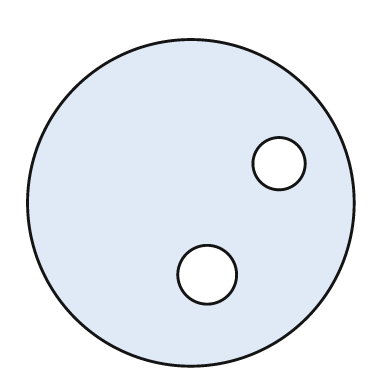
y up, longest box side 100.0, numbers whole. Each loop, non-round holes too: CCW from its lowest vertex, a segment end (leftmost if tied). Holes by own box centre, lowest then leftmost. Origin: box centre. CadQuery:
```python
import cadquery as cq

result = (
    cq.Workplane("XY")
    .moveTo(0.0, 0.0)
    .circle(50.0)
    .moveTo(5.0, -22.0)
    .circle(9.0)
    .moveTo(27.0, 12.0)
    .circle(8.0)
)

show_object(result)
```